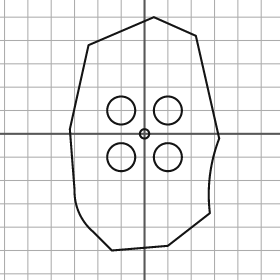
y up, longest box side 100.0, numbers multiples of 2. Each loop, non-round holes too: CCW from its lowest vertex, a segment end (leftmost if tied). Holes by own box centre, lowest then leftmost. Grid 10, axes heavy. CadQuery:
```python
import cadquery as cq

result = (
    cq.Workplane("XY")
    .moveTo(-14.0, -50.0)
    .lineTo(10.0, -48.0)
    .lineTo(28.0, -34.0)
    .threePointArc((28.0, -18.0), (32.0, -2.0))
    .lineTo(22.0, 42.0)
    .lineTo(4.0, 50.0)
    .lineTo(-24.0, 38.0)
    .lineTo(-32.0, 2.0)
    .lineTo(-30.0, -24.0)
    .threePointArc((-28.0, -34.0), (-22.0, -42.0))
    .close()
    .moveTo(-10.0, -10.0)
    .circle(6.0)
    .moveTo(10.0, -10.0)
    .circle(6.0)
    .moveTo(0.0, 0.0)
    .circle(2.0)
    .moveTo(-10.0, 10.0)
    .circle(6.0)
    .moveTo(10.0, 10.0)
    .circle(6.0)
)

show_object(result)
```